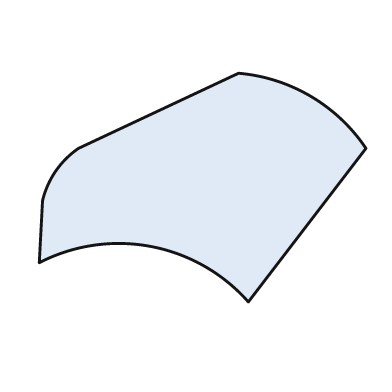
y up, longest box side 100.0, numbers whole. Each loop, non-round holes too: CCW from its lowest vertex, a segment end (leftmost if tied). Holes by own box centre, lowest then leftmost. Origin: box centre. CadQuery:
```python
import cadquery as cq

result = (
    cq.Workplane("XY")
    .moveTo(14.0, -35.0)
    .lineTo(50.0, 12.0)
    .threePointArc((33.0, 28.0), (11.0, 35.0))
    .lineTo(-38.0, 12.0)
    .threePointArc((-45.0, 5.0), (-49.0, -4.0))
    .lineTo(-50.0, -23.0)
    .threePointArc((-16.0, -18.0), (14.0, -35.0))
    .close()
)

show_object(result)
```